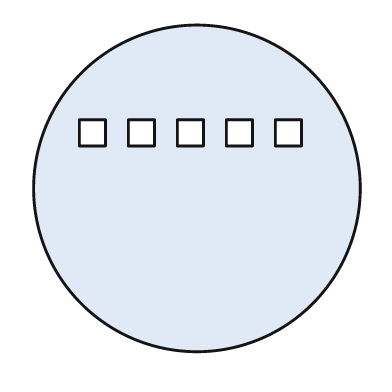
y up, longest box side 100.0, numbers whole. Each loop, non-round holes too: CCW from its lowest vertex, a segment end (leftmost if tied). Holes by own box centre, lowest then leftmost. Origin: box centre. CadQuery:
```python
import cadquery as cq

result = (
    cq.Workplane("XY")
    .moveTo(0.0, 0.0)
    .circle(50.0)
    .moveTo(-36.0, 13.0)
    .lineTo(-28.0, 13.0)
    .lineTo(-28.0, 21.0)
    .lineTo(-36.0, 21.0)
    .close()
    .moveTo(-21.0, 13.0)
    .lineTo(-13.0, 13.0)
    .lineTo(-13.0, 21.0)
    .lineTo(-21.0, 21.0)
    .close()
    .moveTo(-6.0, 13.0)
    .lineTo(2.0, 13.0)
    .lineTo(2.0, 21.0)
    .lineTo(-6.0, 21.0)
    .close()
    .moveTo(9.0, 13.0)
    .lineTo(17.0, 13.0)
    .lineTo(17.0, 21.0)
    .lineTo(9.0, 21.0)
    .close()
    .moveTo(24.0, 13.0)
    .lineTo(32.0, 13.0)
    .lineTo(32.0, 21.0)
    .lineTo(24.0, 21.0)
    .close()
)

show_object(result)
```